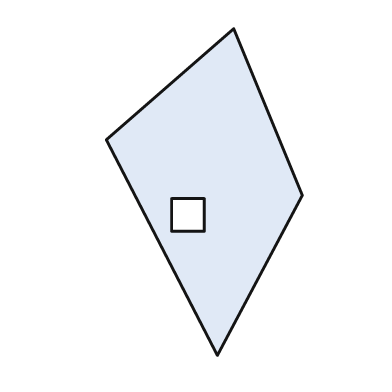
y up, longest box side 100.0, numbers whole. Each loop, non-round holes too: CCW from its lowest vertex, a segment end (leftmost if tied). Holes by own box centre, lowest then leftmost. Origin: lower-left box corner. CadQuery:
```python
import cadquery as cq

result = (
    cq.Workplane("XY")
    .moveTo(34.0, 0.0)
    .lineTo(60.0, 49.0)
    .lineTo(39.0, 100.0)
    .lineTo(0.0, 66.0)
    .close()
    .moveTo(20.0, 38.0)
    .lineTo(30.0, 38.0)
    .lineTo(30.0, 48.0)
    .lineTo(20.0, 48.0)
    .close()
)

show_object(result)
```